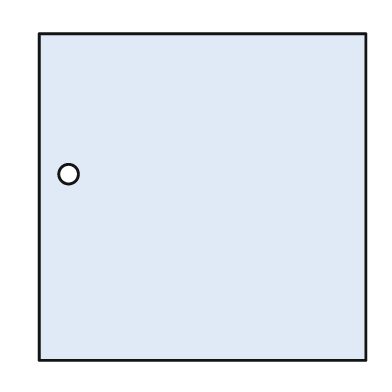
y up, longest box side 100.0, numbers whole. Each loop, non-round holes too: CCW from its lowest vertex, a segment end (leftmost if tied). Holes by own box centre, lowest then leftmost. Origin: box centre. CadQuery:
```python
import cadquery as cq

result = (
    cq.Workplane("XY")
    .moveTo(-50.0, -50.0)
    .lineTo(50.0, -50.0)
    .lineTo(50.0, 50.0)
    .lineTo(-50.0, 50.0)
    .close()
    .moveTo(-41.0, 7.0)
    .circle(3.0)
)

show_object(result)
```